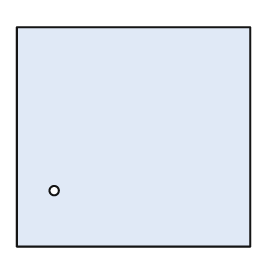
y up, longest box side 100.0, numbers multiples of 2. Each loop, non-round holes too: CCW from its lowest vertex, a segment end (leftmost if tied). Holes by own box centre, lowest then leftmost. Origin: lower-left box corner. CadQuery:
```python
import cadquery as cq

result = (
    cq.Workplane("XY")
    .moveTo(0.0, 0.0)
    .lineTo(100.0, 0.0)
    .lineTo(100.0, 94.0)
    .lineTo(0.0, 94.0)
    .close()
    .moveTo(16.0, 24.0)
    .circle(2.0)
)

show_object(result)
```